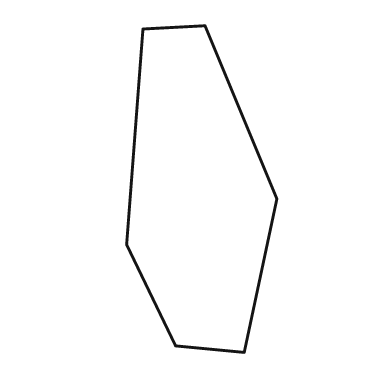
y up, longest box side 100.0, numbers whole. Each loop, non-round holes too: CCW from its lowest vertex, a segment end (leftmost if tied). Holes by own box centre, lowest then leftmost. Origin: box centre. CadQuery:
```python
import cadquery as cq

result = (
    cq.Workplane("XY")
    .moveTo(13.0, -50.0)
    .lineTo(23.0, -3.0)
    .lineTo(1.0, 50.0)
    .lineTo(-18.0, 49.0)
    .lineTo(-23.0, -17.0)
    .lineTo(-8.0, -48.0)
    .close()
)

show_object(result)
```